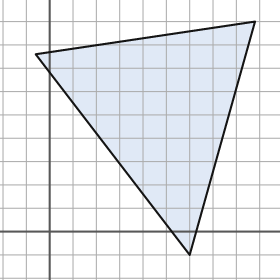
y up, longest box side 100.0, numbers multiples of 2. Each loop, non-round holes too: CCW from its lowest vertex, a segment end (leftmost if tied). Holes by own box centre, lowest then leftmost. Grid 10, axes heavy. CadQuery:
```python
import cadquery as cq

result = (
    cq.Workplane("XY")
    .moveTo(60.0, -10.0)
    .lineTo(88.0, 90.0)
    .lineTo(-6.0, 76.0)
    .close()
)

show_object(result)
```